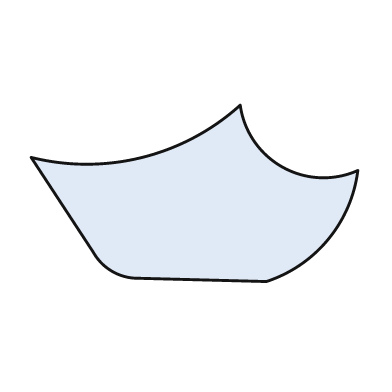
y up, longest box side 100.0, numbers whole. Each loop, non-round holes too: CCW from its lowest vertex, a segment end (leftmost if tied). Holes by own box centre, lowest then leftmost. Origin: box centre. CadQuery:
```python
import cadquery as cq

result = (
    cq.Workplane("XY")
    .moveTo(22.0, -27.0)
    .threePointArc((41.0, -14.0), (50.0, 7.0))
    .threePointArc((27.0, 8.0), (14.0, 27.0))
    .threePointArc((-16.0, 11.0), (-50.0, 11.0))
    .lineTo(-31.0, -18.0)
    .threePointArc((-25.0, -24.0), (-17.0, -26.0))
    .close()
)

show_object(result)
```